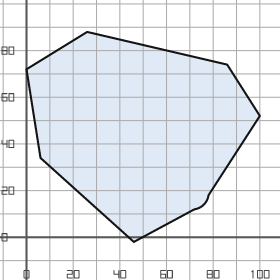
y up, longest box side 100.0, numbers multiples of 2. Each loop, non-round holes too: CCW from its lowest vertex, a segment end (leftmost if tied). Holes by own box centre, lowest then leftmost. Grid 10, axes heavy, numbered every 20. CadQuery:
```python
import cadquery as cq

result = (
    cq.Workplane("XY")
    .moveTo(46.0, -2.0)
    .lineTo(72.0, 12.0)
    .threePointArc((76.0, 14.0), (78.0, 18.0))
    .lineTo(100.0, 52.0)
    .lineTo(86.0, 74.0)
    .lineTo(26.0, 88.0)
    .lineTo(0.0, 72.0)
    .lineTo(6.0, 34.0)
    .close()
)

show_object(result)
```